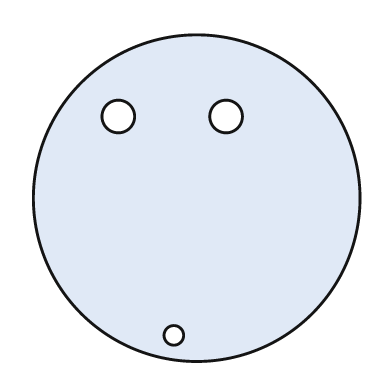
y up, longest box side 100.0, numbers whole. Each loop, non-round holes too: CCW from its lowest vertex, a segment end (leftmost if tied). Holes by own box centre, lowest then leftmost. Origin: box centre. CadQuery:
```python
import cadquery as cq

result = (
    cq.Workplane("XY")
    .moveTo(0.0, 0.0)
    .circle(50.0)
    .moveTo(-7.0, -42.0)
    .circle(3.0)
    .moveTo(-24.0, 25.0)
    .circle(5.0)
    .moveTo(9.0, 25.0)
    .circle(5.0)
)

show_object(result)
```